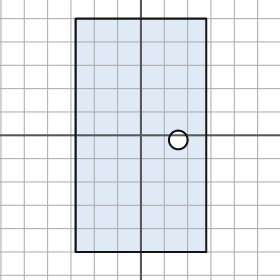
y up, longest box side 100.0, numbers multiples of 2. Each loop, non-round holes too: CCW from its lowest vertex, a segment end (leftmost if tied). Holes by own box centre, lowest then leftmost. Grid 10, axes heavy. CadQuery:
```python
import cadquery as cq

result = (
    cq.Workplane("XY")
    .moveTo(-28.0, -50.0)
    .lineTo(28.0, -50.0)
    .lineTo(28.0, 50.0)
    .lineTo(-28.0, 50.0)
    .close()
    .moveTo(16.0, -2.0)
    .circle(4.0)
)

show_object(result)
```